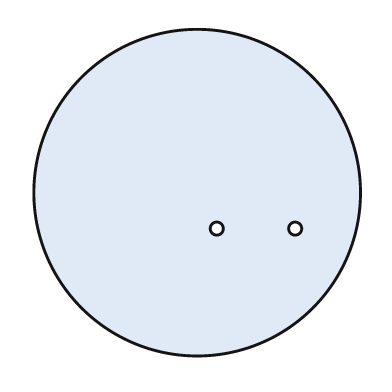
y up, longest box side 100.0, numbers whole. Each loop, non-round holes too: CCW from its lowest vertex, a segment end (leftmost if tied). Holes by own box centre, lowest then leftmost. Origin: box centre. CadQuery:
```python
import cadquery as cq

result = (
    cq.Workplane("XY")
    .moveTo(0.0, 0.0)
    .circle(50.0)
    .moveTo(6.0, -11.0)
    .circle(2.0)
    .moveTo(30.0, -11.0)
    .circle(2.0)
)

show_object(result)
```